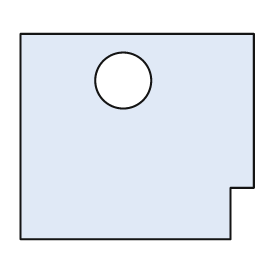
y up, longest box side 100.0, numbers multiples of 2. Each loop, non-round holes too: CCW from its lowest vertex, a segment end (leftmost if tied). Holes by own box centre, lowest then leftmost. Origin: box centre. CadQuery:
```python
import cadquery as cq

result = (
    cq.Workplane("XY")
    .moveTo(-50.0, -44.0)
    .lineTo(40.0, -44.0)
    .lineTo(40.0, -22.0)
    .lineTo(50.0, -22.0)
    .lineTo(50.0, 44.0)
    .lineTo(-50.0, 44.0)
    .close()
    .moveTo(-6.0, 24.0)
    .circle(12.0)
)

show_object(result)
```